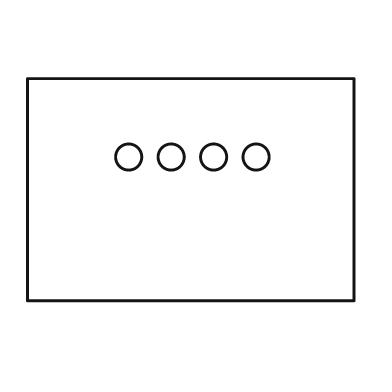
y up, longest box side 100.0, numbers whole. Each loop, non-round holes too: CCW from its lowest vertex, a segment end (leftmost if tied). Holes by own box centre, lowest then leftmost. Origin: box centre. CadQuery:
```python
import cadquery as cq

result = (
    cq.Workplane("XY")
    .moveTo(-50.0, -34.0)
    .lineTo(50.0, -34.0)
    .lineTo(50.0, 34.0)
    .lineTo(-50.0, 34.0)
    .close()
    .moveTo(-19.0, 10.0)
    .circle(4.0)
    .moveTo(-6.0, 10.0)
    .circle(4.0)
    .moveTo(7.0, 10.0)
    .circle(4.0)
    .moveTo(20.0, 10.0)
    .circle(4.0)
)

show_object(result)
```